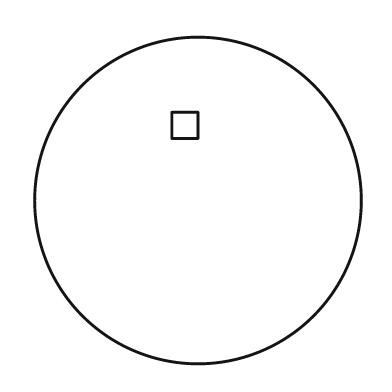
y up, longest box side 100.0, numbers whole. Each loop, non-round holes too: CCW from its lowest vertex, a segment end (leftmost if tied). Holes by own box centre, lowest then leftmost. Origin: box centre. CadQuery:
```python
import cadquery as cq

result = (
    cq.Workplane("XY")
    .moveTo(0.0, 0.0)
    .circle(50.0)
    .moveTo(-8.0, 19.0)
    .lineTo(0.0, 19.0)
    .lineTo(0.0, 27.0)
    .lineTo(-8.0, 27.0)
    .close()
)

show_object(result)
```